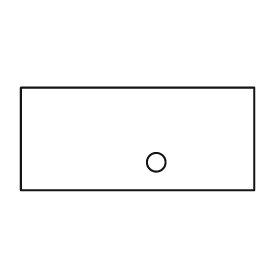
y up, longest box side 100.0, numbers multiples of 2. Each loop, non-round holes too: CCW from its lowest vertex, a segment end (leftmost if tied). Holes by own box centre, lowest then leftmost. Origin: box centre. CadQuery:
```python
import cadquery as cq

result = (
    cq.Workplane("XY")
    .moveTo(-50.0, -22.0)
    .lineTo(50.0, -22.0)
    .lineTo(50.0, 22.0)
    .lineTo(-50.0, 22.0)
    .close()
    .moveTo(8.0, -10.0)
    .circle(4.0)
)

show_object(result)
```